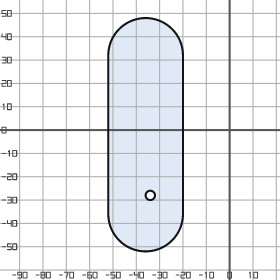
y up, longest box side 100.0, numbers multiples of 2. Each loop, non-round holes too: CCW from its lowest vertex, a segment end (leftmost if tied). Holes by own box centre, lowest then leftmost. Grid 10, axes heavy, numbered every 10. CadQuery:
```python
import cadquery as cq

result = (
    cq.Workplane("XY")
    .moveTo(-52.0, -36.0)
    .threePointArc((-36.0, -52.0), (-20.0, -36.0))
    .lineTo(-20.0, 32.0)
    .threePointArc((-36.0, 48.0), (-52.0, 32.0))
    .close()
    .moveTo(-34.0, -28.0)
    .circle(2.0)
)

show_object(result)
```